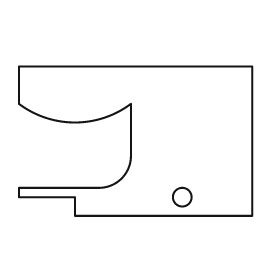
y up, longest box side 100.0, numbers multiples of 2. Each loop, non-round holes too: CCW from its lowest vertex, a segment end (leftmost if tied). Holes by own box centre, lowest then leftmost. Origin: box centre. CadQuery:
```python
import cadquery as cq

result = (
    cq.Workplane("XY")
    .moveTo(-26.0, -32.0)
    .lineTo(50.0, -32.0)
    .lineTo(50.0, 32.0)
    .lineTo(-50.0, 32.0)
    .lineTo(-50.0, 16.0)
    .threePointArc((-26.0, 8.0), (-2.0, 16.0))
    .lineTo(-2.0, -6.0)
    .threePointArc((-6.0, -16.0), (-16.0, -20.0))
    .lineTo(-50.0, -20.0)
    .lineTo(-50.0, -24.0)
    .lineTo(-26.0, -24.0)
    .close()
    .moveTo(20.0, -24.0)
    .circle(4.0)
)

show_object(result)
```